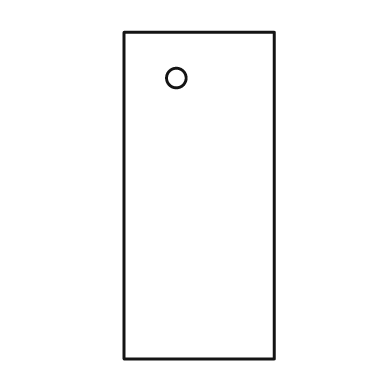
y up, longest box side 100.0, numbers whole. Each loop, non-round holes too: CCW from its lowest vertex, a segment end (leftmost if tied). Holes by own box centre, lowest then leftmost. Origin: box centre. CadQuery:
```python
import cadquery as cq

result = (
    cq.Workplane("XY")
    .moveTo(-23.0, -50.0)
    .lineTo(23.0, -50.0)
    .lineTo(23.0, 50.0)
    .lineTo(-23.0, 50.0)
    .close()
    .moveTo(-7.0, 36.0)
    .circle(3.0)
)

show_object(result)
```